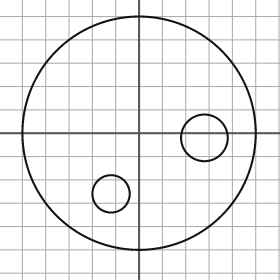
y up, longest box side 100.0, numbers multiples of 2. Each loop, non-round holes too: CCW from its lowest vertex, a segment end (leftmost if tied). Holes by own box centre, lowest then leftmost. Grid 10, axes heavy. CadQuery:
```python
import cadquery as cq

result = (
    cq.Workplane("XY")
    .moveTo(0.0, 0.0)
    .circle(50.0)
    .moveTo(-12.0, -26.0)
    .circle(8.0)
    .moveTo(28.0, -2.0)
    .circle(10.0)
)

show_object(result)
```